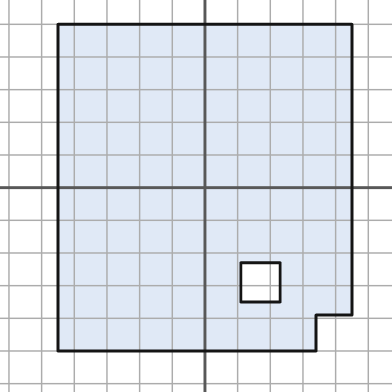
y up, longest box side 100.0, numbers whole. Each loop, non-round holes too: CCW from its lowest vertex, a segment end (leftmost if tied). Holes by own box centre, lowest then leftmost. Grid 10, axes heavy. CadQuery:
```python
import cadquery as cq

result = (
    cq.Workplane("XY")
    .moveTo(-45.0, -50.0)
    .lineTo(34.0, -50.0)
    .lineTo(34.0, -39.0)
    .lineTo(45.0, -39.0)
    .lineTo(45.0, 50.0)
    .lineTo(-45.0, 50.0)
    .close()
    .moveTo(11.0, -35.0)
    .lineTo(23.0, -35.0)
    .lineTo(23.0, -23.0)
    .lineTo(11.0, -23.0)
    .close()
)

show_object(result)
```